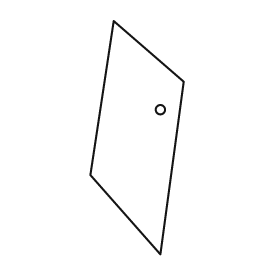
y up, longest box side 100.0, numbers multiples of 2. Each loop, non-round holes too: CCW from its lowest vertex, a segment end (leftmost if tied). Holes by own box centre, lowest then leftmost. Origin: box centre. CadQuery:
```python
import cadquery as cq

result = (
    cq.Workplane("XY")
    .moveTo(10.0, -50.0)
    .lineTo(20.0, 24.0)
    .lineTo(-10.0, 50.0)
    .lineTo(-20.0, -16.0)
    .close()
    .moveTo(10.0, 12.0)
    .circle(2.0)
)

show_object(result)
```